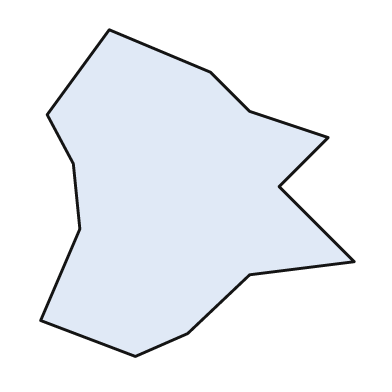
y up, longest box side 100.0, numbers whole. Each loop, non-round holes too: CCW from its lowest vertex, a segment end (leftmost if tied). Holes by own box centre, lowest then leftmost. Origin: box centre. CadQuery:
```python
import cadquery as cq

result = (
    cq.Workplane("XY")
    .moveTo(-19.0, -50.0)
    .lineTo(-3.0, -43.0)
    .lineTo(16.0, -25.0)
    .lineTo(48.0, -21.0)
    .lineTo(25.0, 2.0)
    .lineTo(40.0, 17.0)
    .lineTo(16.0, 25.0)
    .lineTo(4.0, 37.0)
    .lineTo(-27.0, 50.0)
    .lineTo(-46.0, 24.0)
    .lineTo(-38.0, 9.0)
    .lineTo(-36.0, -11.0)
    .lineTo(-48.0, -39.0)
    .close()
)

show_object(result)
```